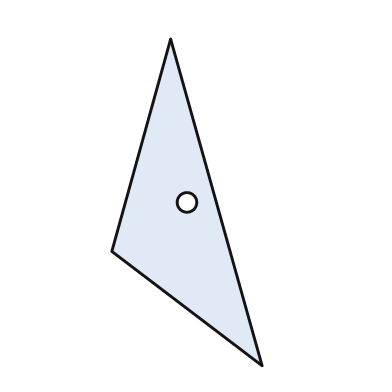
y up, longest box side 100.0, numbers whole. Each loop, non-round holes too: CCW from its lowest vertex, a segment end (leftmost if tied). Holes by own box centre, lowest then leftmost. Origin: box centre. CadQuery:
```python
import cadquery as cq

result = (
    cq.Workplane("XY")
    .moveTo(23.0, -50.0)
    .lineTo(-5.0, 50.0)
    .lineTo(-23.0, -15.0)
    .close()
    .moveTo(0.0, 0.0)
    .circle(3.0)
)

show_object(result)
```